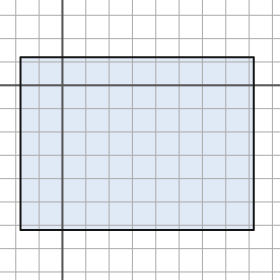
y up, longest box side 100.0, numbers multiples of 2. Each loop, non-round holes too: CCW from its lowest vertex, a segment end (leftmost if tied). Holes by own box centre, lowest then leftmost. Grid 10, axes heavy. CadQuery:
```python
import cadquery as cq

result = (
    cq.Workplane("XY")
    .moveTo(-18.0, -62.0)
    .lineTo(82.0, -62.0)
    .lineTo(82.0, 12.0)
    .lineTo(-18.0, 12.0)
    .close()
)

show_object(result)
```